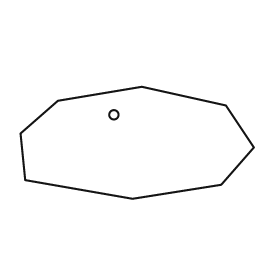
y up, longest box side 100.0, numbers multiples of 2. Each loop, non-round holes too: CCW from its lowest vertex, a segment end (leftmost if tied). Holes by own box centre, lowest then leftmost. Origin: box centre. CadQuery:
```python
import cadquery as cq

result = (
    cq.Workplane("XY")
    .moveTo(-2.0, -24.0)
    .lineTo(36.0, -18.0)
    .lineTo(50.0, -2.0)
    .lineTo(38.0, 16.0)
    .lineTo(2.0, 24.0)
    .lineTo(-34.0, 18.0)
    .lineTo(-50.0, 4.0)
    .lineTo(-48.0, -16.0)
    .close()
    .moveTo(-10.0, 12.0)
    .circle(2.0)
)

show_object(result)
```